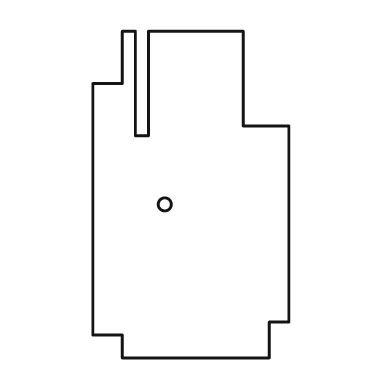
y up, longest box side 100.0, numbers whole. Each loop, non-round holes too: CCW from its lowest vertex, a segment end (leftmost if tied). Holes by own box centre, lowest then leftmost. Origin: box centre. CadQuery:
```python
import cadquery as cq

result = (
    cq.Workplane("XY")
    .moveTo(-21.0, -50.0)
    .lineTo(24.0, -50.0)
    .lineTo(24.0, -39.0)
    .lineTo(30.0, -39.0)
    .lineTo(30.0, 21.0)
    .lineTo(16.0, 21.0)
    .lineTo(16.0, 50.0)
    .lineTo(-13.0, 50.0)
    .lineTo(-13.0, 18.0)
    .lineTo(-17.0, 18.0)
    .lineTo(-17.0, 50.0)
    .lineTo(-21.0, 50.0)
    .lineTo(-21.0, 34.0)
    .lineTo(-30.0, 34.0)
    .lineTo(-30.0, -43.0)
    .lineTo(-21.0, -43.0)
    .close()
    .moveTo(-8.0, -3.0)
    .circle(2.0)
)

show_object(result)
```